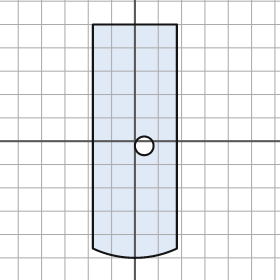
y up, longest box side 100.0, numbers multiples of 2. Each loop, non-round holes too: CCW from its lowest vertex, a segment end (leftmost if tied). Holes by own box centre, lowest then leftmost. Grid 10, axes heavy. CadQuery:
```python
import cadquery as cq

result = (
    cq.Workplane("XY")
    .moveTo(-18.0, -46.0)
    .threePointArc((0.0, -50.0), (18.0, -46.0))
    .lineTo(18.0, 50.0)
    .lineTo(-18.0, 50.0)
    .close()
    .moveTo(4.0, -2.0)
    .circle(4.0)
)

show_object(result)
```